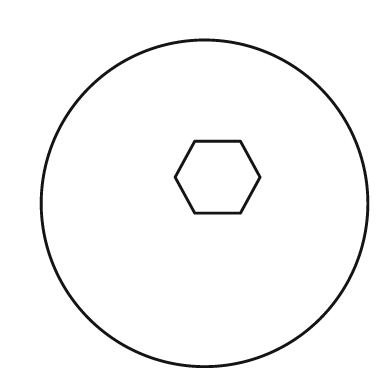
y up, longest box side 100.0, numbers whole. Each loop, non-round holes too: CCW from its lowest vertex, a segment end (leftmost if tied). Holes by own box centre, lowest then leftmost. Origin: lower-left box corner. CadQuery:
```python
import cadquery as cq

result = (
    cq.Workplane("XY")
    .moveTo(50.0, 50.0)
    .circle(50.0)
    .moveTo(47.0, 47.0)
    .lineTo(61.0, 47.0)
    .lineTo(67.0, 58.0)
    .lineTo(61.0, 69.0)
    .lineTo(47.0, 69.0)
    .lineTo(41.0, 58.0)
    .close()
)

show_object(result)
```